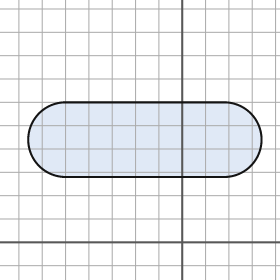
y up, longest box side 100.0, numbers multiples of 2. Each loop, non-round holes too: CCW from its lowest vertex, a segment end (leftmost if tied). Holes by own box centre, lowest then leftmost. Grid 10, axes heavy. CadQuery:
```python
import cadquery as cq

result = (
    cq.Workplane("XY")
    .moveTo(-50.0, 28.0)
    .lineTo(18.0, 28.0)
    .threePointArc((34.0, 44.0), (18.0, 60.0))
    .lineTo(-50.0, 60.0)
    .threePointArc((-66.0, 44.0), (-50.0, 28.0))
    .close()
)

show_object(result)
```